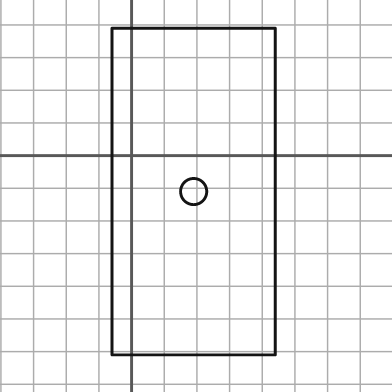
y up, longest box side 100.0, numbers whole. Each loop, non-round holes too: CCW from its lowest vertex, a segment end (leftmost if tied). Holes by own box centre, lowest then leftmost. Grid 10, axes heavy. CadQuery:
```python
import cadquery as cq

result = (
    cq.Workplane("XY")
    .moveTo(-6.0, -61.0)
    .lineTo(44.0, -61.0)
    .lineTo(44.0, 39.0)
    .lineTo(-6.0, 39.0)
    .close()
    .moveTo(19.0, -11.0)
    .circle(4.0)
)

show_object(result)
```